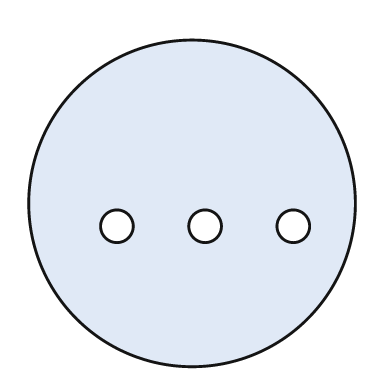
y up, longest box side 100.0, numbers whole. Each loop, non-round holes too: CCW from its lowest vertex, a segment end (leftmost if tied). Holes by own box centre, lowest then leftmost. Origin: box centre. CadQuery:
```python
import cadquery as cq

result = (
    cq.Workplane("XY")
    .moveTo(0.0, 0.0)
    .circle(50.0)
    .moveTo(-23.0, -7.0)
    .circle(5.0)
    .moveTo(4.0, -7.0)
    .circle(5.0)
    .moveTo(31.0, -7.0)
    .circle(5.0)
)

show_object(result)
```